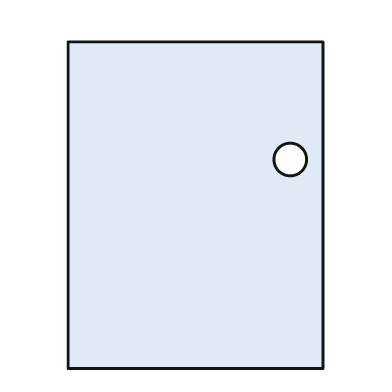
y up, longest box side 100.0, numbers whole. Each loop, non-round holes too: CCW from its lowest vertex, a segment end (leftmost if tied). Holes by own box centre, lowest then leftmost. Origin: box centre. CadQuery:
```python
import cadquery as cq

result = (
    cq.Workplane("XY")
    .moveTo(-39.0, -50.0)
    .lineTo(39.0, -50.0)
    .lineTo(39.0, 50.0)
    .lineTo(-39.0, 50.0)
    .close()
    .moveTo(29.0, 14.0)
    .circle(5.0)
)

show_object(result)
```